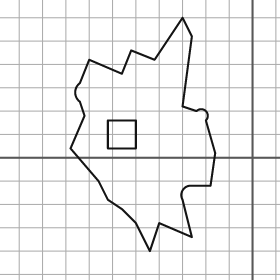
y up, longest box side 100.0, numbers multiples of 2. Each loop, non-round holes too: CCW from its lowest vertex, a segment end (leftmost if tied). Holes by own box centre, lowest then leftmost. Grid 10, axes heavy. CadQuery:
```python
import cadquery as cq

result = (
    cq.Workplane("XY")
    .moveTo(-44.0, -40.0)
    .lineTo(-40.0, -28.0)
    .lineTo(-26.0, -34.0)
    .lineTo(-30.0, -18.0)
    .threePointArc((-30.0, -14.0), (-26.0, -12.0))
    .lineTo(-18.0, -12.0)
    .lineTo(-16.0, 2.0)
    .lineTo(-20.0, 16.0)
    .threePointArc((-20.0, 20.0), (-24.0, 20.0))
    .lineTo(-30.0, 22.0)
    .lineTo(-26.0, 52.0)
    .lineTo(-30.0, 60.0)
    .lineTo(-42.0, 42.0)
    .lineTo(-52.0, 46.0)
    .lineTo(-56.0, 36.0)
    .lineTo(-70.0, 42.0)
    .lineTo(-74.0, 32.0)
    .threePointArc((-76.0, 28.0), (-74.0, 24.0))
    .lineTo(-72.0, 18.0)
    .lineTo(-78.0, 4.0)
    .lineTo(-66.0, -10.0)
    .lineTo(-62.0, -18.0)
    .lineTo(-56.0, -22.0)
    .lineTo(-50.0, -28.0)
    .close()
    .moveTo(-62.0, 4.0)
    .lineTo(-50.0, 4.0)
    .lineTo(-50.0, 16.0)
    .lineTo(-62.0, 16.0)
    .close()
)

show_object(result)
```